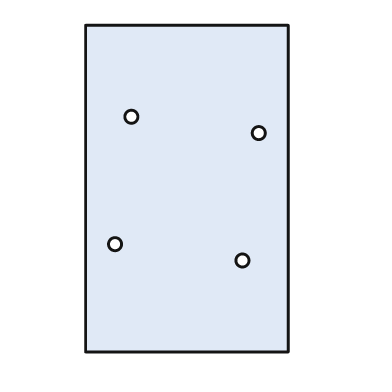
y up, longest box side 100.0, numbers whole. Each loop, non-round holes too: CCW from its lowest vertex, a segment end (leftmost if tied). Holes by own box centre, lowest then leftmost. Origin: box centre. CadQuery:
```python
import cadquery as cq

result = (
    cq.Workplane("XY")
    .moveTo(-31.0, -50.0)
    .lineTo(31.0, -50.0)
    .lineTo(31.0, 50.0)
    .lineTo(-31.0, 50.0)
    .close()
    .moveTo(17.0, -22.0)
    .circle(2.0)
    .moveTo(-22.0, -17.0)
    .circle(2.0)
    .moveTo(22.0, 17.0)
    .circle(2.0)
    .moveTo(-17.0, 22.0)
    .circle(2.0)
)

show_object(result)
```